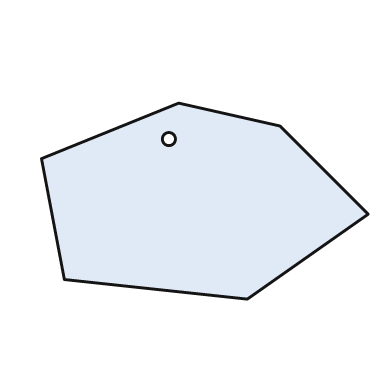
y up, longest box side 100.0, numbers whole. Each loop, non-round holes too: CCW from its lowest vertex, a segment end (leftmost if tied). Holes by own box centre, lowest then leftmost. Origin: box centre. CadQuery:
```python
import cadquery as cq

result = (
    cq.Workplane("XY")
    .moveTo(13.0, -30.0)
    .lineTo(50.0, -4.0)
    .lineTo(23.0, 23.0)
    .lineTo(-8.0, 30.0)
    .lineTo(-50.0, 13.0)
    .lineTo(-43.0, -24.0)
    .close()
    .moveTo(-11.0, 19.0)
    .circle(2.0)
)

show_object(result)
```